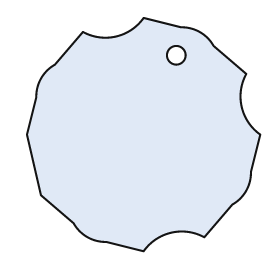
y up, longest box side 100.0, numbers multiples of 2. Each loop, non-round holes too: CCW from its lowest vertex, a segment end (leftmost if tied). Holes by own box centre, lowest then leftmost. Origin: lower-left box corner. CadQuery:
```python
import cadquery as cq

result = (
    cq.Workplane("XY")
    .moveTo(50.0, 0.0)
    .threePointArc((62.0, 8.0), (76.0, 6.0))
    .lineTo(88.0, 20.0)
    .threePointArc((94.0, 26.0), (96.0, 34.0))
    .lineTo(100.0, 50.0)
    .threePointArc((92.0, 62.0), (94.0, 76.0))
    .lineTo(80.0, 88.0)
    .threePointArc((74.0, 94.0), (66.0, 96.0))
    .lineTo(50.0, 100.0)
    .threePointArc((38.0, 92.0), (24.0, 94.0))
    .lineTo(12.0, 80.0)
    .threePointArc((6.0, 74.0), (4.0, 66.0))
    .lineTo(0.0, 50.0)
    .lineTo(6.0, 24.0)
    .lineTo(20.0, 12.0)
    .threePointArc((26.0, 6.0), (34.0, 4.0))
    .close()
    .moveTo(64.0, 84.0)
    .circle(4.0)
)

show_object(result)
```